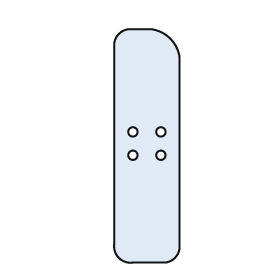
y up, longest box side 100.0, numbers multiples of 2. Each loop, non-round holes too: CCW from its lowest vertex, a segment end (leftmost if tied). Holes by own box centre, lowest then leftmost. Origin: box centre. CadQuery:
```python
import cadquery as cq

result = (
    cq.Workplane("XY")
    .moveTo(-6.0, -50.0)
    .lineTo(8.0, -50.0)
    .threePointArc((12.0, -48.0), (14.0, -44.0))
    .lineTo(14.0, 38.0)
    .threePointArc((10.0, 46.0), (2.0, 50.0))
    .lineTo(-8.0, 50.0)
    .threePointArc((-12.0, 48.0), (-14.0, 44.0))
    .lineTo(-14.0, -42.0)
    .threePointArc((-12.0, -48.0), (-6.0, -50.0))
    .close()
    .moveTo(-6.0, -4.0)
    .circle(2.0)
    .moveTo(6.0, -4.0)
    .circle(2.0)
    .moveTo(-6.0, 6.0)
    .circle(2.0)
    .moveTo(6.0, 6.0)
    .circle(2.0)
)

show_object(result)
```